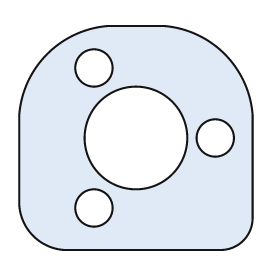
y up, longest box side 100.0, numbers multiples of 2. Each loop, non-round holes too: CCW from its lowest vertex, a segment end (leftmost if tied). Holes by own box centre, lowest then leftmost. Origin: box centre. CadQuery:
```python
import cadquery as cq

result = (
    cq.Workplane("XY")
    .moveTo(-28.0, -48.0)
    .lineTo(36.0, -48.0)
    .threePointArc((46.0, -44.0), (50.0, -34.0))
    .lineTo(50.0, 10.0)
    .threePointArc((38.0, 36.0), (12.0, 48.0))
    .lineTo(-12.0, 48.0)
    .threePointArc((-38.0, 36.0), (-50.0, 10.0))
    .lineTo(-50.0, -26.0)
    .threePointArc((-44.0, -42.0), (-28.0, -48.0))
    .close()
    .moveTo(-18.0, -30.0)
    .circle(8.0)
    .moveTo(0.0, 0.0)
    .circle(22.0)
    .moveTo(34.0, 0.0)
    .circle(8.0)
    .moveTo(-18.0, 30.0)
    .circle(8.0)
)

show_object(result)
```